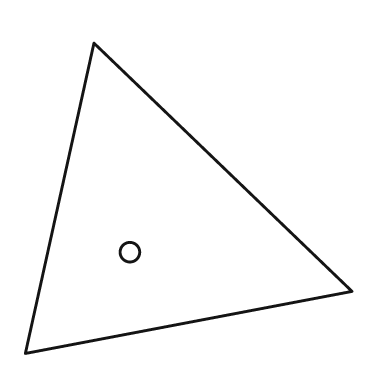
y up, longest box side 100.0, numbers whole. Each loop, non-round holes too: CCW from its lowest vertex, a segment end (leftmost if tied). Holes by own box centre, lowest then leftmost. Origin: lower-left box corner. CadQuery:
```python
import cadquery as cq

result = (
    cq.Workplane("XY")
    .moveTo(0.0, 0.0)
    .lineTo(100.0, 19.0)
    .lineTo(21.0, 95.0)
    .close()
    .moveTo(32.0, 31.0)
    .circle(3.0)
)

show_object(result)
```